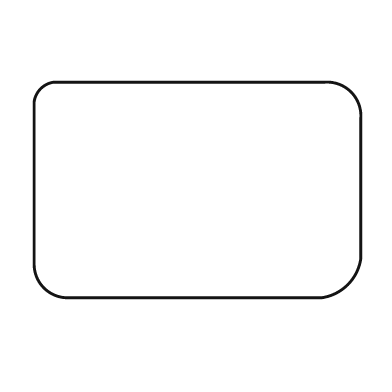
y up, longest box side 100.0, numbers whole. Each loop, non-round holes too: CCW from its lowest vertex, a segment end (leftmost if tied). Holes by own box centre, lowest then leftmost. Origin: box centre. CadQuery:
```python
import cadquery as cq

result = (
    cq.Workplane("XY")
    .moveTo(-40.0, -33.0)
    .lineTo(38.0, -33.0)
    .threePointArc((46.0, -29.0), (50.0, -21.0))
    .lineTo(50.0, 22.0)
    .threePointArc((47.0, 30.0), (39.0, 33.0))
    .lineTo(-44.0, 33.0)
    .threePointArc((-48.0, 31.0), (-50.0, 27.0))
    .lineTo(-50.0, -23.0)
    .threePointArc((-47.0, -30.0), (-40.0, -33.0))
    .close()
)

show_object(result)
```